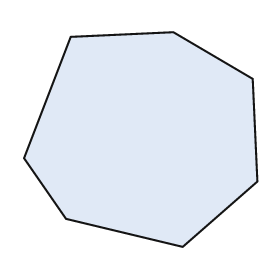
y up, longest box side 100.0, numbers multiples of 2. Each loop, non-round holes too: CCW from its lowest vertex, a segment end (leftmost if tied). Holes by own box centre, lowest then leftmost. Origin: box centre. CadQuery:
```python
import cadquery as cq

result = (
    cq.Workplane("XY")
    .moveTo(18.0, -46.0)
    .lineTo(50.0, -18.0)
    .lineTo(48.0, 26.0)
    .lineTo(14.0, 46.0)
    .lineTo(-30.0, 44.0)
    .lineTo(-50.0, -8.0)
    .lineTo(-32.0, -34.0)
    .close()
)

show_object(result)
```